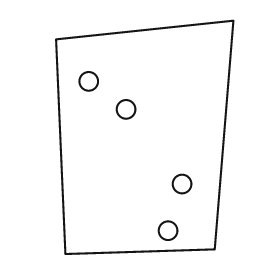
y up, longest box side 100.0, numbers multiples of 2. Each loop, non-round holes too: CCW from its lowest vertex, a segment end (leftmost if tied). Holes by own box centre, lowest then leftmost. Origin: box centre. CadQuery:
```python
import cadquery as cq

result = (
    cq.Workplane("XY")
    .moveTo(-34.0, -50.0)
    .lineTo(30.0, -48.0)
    .lineTo(38.0, 50.0)
    .lineTo(-38.0, 42.0)
    .close()
    .moveTo(10.0, -40.0)
    .circle(4.0)
    .moveTo(16.0, -20.0)
    .circle(4.0)
    .moveTo(-8.0, 12.0)
    .circle(4.0)
    .moveTo(-24.0, 24.0)
    .circle(4.0)
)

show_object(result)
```